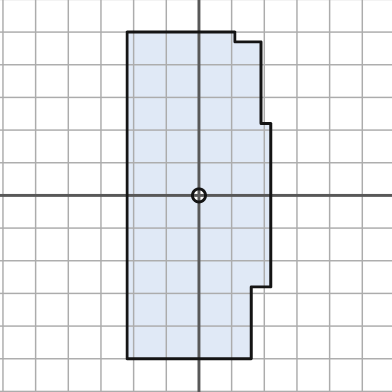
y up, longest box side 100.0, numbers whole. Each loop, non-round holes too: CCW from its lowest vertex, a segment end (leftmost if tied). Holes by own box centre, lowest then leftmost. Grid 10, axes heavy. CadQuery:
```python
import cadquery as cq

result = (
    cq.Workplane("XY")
    .moveTo(-22.0, -50.0)
    .lineTo(16.0, -50.0)
    .lineTo(16.0, -28.0)
    .lineTo(22.0, -28.0)
    .lineTo(22.0, 22.0)
    .lineTo(19.0, 22.0)
    .lineTo(19.0, 47.0)
    .lineTo(11.0, 47.0)
    .lineTo(11.0, 50.0)
    .lineTo(-22.0, 50.0)
    .close()
    .moveTo(0.0, 0.0)
    .circle(2.0)
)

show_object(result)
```